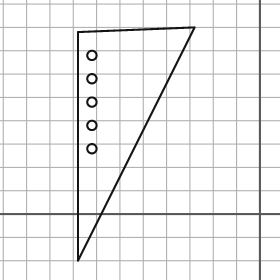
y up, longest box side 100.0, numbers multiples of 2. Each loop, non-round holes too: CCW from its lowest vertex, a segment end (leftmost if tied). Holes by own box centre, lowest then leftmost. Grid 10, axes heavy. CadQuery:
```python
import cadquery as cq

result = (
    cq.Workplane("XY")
    .moveTo(-78.0, -20.0)
    .lineTo(-28.0, 80.0)
    .lineTo(-78.0, 78.0)
    .close()
    .moveTo(-72.0, 28.0)
    .circle(2.0)
    .moveTo(-72.0, 38.0)
    .circle(2.0)
    .moveTo(-72.0, 48.0)
    .circle(2.0)
    .moveTo(-72.0, 58.0)
    .circle(2.0)
    .moveTo(-72.0, 68.0)
    .circle(2.0)
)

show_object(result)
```